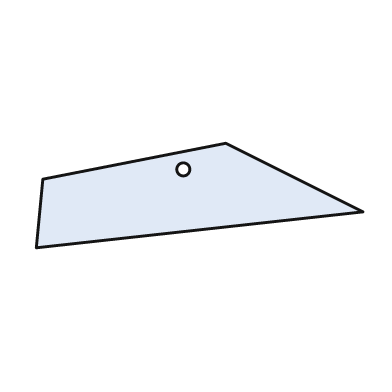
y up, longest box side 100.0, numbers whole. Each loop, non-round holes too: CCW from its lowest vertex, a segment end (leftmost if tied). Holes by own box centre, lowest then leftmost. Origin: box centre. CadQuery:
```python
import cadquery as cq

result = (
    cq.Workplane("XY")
    .moveTo(-50.0, -16.0)
    .lineTo(50.0, -5.0)
    .lineTo(8.0, 16.0)
    .lineTo(-48.0, 5.0)
    .close()
    .moveTo(-5.0, 8.0)
    .circle(2.0)
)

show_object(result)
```